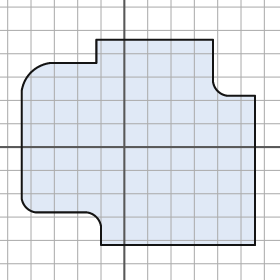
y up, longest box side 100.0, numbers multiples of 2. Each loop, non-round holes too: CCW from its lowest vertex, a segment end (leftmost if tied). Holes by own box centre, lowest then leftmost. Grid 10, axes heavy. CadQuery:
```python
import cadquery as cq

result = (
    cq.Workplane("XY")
    .moveTo(-10.0, -42.0)
    .lineTo(56.0, -42.0)
    .lineTo(56.0, 22.0)
    .lineTo(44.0, 22.0)
    .threePointArc((40.0, 24.0), (38.0, 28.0))
    .lineTo(38.0, 46.0)
    .lineTo(-12.0, 46.0)
    .lineTo(-12.0, 36.0)
    .lineTo(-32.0, 36.0)
    .threePointArc((-40.0, 32.0), (-44.0, 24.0))
    .lineTo(-44.0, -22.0)
    .threePointArc((-42.0, -26.0), (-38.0, -28.0))
    .lineTo(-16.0, -28.0)
    .threePointArc((-12.0, -30.0), (-10.0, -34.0))
    .close()
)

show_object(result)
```